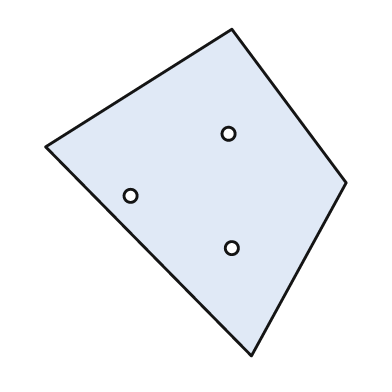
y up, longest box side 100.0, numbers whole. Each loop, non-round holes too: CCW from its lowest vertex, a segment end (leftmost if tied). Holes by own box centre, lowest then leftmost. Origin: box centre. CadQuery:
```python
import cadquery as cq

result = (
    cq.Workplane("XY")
    .moveTo(17.0, -50.0)
    .lineTo(46.0, 3.0)
    .lineTo(11.0, 50.0)
    .lineTo(-46.0, 14.0)
    .close()
    .moveTo(11.0, -17.0)
    .circle(2.0)
    .moveTo(-20.0, -1.0)
    .circle(2.0)
    .moveTo(10.0, 18.0)
    .circle(2.0)
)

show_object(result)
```